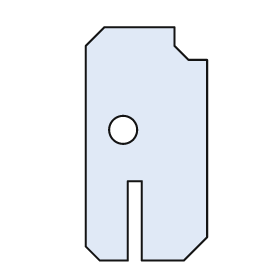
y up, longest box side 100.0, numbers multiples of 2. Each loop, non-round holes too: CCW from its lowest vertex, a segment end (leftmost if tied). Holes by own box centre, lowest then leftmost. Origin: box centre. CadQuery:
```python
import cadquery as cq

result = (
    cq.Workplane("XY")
    .moveTo(-20.0, -50.0)
    .lineTo(-8.0, -50.0)
    .lineTo(-8.0, -16.0)
    .lineTo(-2.0, -16.0)
    .lineTo(-2.0, -50.0)
    .lineTo(16.0, -50.0)
    .lineTo(26.0, -40.0)
    .lineTo(26.0, 36.0)
    .lineTo(18.0, 36.0)
    .lineTo(12.0, 42.0)
    .lineTo(12.0, 50.0)
    .lineTo(-18.0, 50.0)
    .lineTo(-26.0, 42.0)
    .lineTo(-26.0, -44.0)
    .close()
    .moveTo(-10.0, 6.0)
    .circle(6.0)
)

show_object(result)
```